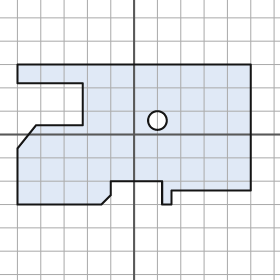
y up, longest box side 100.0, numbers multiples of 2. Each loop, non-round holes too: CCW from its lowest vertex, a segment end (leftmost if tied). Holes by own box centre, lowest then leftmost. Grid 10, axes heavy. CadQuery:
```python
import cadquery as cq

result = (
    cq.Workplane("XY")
    .moveTo(-50.0, -30.0)
    .lineTo(-14.0, -30.0)
    .lineTo(-10.0, -26.0)
    .lineTo(-10.0, -20.0)
    .lineTo(12.0, -20.0)
    .lineTo(12.0, -30.0)
    .lineTo(16.0, -30.0)
    .lineTo(16.0, -24.0)
    .lineTo(50.0, -24.0)
    .lineTo(50.0, 30.0)
    .lineTo(-50.0, 30.0)
    .lineTo(-50.0, 22.0)
    .lineTo(-22.0, 22.0)
    .lineTo(-22.0, 4.0)
    .lineTo(-42.0, 4.0)
    .lineTo(-50.0, -6.0)
    .close()
    .moveTo(10.0, 6.0)
    .circle(4.0)
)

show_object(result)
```